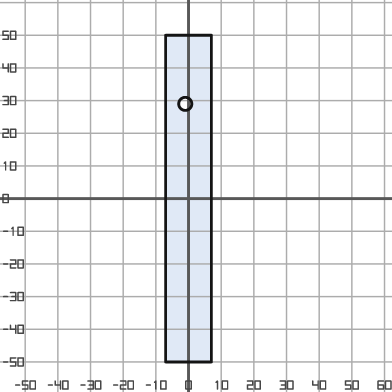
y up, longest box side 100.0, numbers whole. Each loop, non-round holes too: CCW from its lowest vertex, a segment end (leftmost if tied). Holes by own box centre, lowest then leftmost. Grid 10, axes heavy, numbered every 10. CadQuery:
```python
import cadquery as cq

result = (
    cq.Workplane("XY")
    .moveTo(-7.0, -50.0)
    .lineTo(7.0, -50.0)
    .lineTo(7.0, 50.0)
    .lineTo(-7.0, 50.0)
    .close()
    .moveTo(-1.0, 29.0)
    .circle(2.0)
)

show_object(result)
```